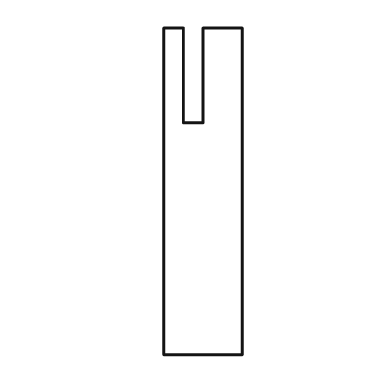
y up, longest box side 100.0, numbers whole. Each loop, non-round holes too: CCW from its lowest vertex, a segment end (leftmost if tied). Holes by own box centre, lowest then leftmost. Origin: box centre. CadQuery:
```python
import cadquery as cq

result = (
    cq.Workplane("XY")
    .moveTo(-12.0, -50.0)
    .lineTo(12.0, -50.0)
    .lineTo(12.0, 50.0)
    .lineTo(0.0, 50.0)
    .lineTo(0.0, 21.0)
    .lineTo(-6.0, 21.0)
    .lineTo(-6.0, 50.0)
    .lineTo(-12.0, 50.0)
    .close()
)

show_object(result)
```